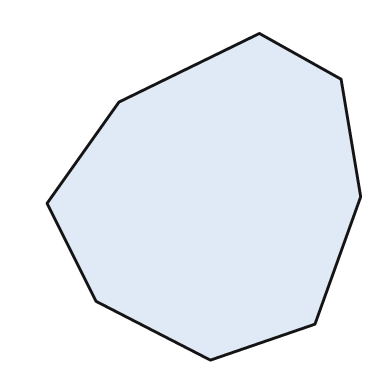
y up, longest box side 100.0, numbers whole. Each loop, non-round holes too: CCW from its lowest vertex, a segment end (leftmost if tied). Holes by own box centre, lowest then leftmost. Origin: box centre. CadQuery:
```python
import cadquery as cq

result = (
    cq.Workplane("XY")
    .moveTo(2.0, -50.0)
    .lineTo(34.0, -39.0)
    .lineTo(48.0, 0.0)
    .lineTo(42.0, 36.0)
    .lineTo(17.0, 50.0)
    .lineTo(-26.0, 29.0)
    .lineTo(-48.0, -2.0)
    .lineTo(-33.0, -32.0)
    .close()
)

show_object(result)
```